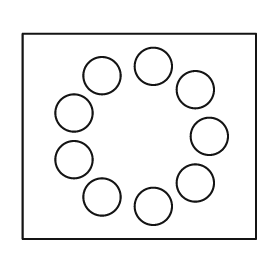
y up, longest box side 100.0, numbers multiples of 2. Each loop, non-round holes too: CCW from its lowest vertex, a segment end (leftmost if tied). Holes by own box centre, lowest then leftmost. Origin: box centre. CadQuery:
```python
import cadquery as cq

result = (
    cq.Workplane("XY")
    .moveTo(-50.0, -44.0)
    .lineTo(50.0, -44.0)
    .lineTo(50.0, 44.0)
    .lineTo(-50.0, 44.0)
    .close()
    .moveTo(6.0, -30.0)
    .circle(8.0)
    .moveTo(-16.0, -26.0)
    .circle(8.0)
    .moveTo(24.0, -20.0)
    .circle(8.0)
    .moveTo(-28.0, -10.0)
    .circle(8.0)
    .moveTo(30.0, 0.0)
    .circle(8.0)
    .moveTo(-28.0, 10.0)
    .circle(8.0)
    .moveTo(24.0, 20.0)
    .circle(8.0)
    .moveTo(-16.0, 26.0)
    .circle(8.0)
    .moveTo(6.0, 30.0)
    .circle(8.0)
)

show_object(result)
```